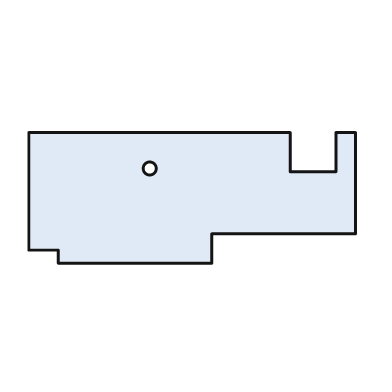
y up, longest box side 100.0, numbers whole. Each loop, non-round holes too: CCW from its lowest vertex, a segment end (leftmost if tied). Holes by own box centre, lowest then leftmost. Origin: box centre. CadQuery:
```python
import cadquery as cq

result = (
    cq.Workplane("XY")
    .moveTo(-41.0, -20.0)
    .lineTo(6.0, -20.0)
    .lineTo(6.0, -11.0)
    .lineTo(50.0, -11.0)
    .lineTo(50.0, 20.0)
    .lineTo(44.0, 20.0)
    .lineTo(44.0, 8.0)
    .lineTo(30.0, 8.0)
    .lineTo(30.0, 20.0)
    .lineTo(-50.0, 20.0)
    .lineTo(-50.0, -16.0)
    .lineTo(-41.0, -16.0)
    .close()
    .moveTo(-13.0, 9.0)
    .circle(2.0)
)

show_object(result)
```